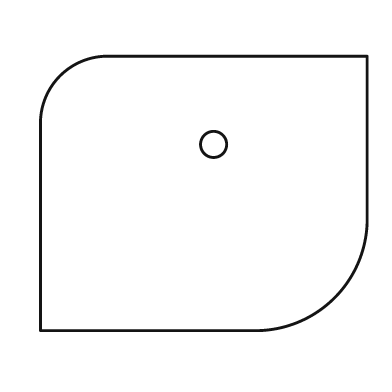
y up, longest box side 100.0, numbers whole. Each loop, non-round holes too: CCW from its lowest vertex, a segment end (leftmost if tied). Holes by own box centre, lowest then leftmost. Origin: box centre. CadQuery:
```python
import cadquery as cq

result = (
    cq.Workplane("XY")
    .moveTo(-50.0, -42.0)
    .lineTo(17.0, -42.0)
    .threePointArc((40.0, -32.0), (50.0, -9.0))
    .lineTo(50.0, 42.0)
    .lineTo(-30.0, 42.0)
    .threePointArc((-44.0, 36.0), (-50.0, 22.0))
    .close()
    .moveTo(3.0, 15.0)
    .circle(4.0)
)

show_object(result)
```